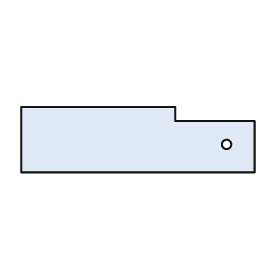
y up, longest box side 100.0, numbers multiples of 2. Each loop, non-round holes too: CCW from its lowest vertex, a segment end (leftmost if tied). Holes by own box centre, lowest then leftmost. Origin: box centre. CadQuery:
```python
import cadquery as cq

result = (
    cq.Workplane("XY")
    .moveTo(-50.0, -14.0)
    .lineTo(50.0, -14.0)
    .lineTo(50.0, 8.0)
    .lineTo(16.0, 8.0)
    .lineTo(16.0, 14.0)
    .lineTo(-50.0, 14.0)
    .close()
    .moveTo(38.0, -2.0)
    .circle(2.0)
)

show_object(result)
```